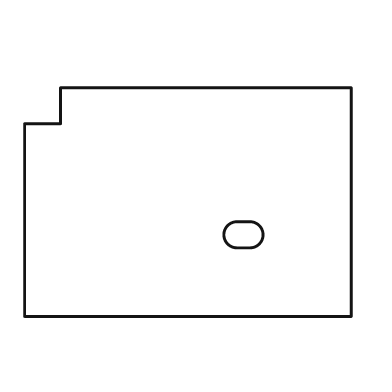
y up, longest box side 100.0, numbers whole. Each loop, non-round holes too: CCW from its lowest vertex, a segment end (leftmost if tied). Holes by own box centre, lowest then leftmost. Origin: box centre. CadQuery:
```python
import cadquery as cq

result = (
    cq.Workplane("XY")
    .moveTo(-50.0, -35.0)
    .lineTo(50.0, -35.0)
    .lineTo(50.0, 35.0)
    .lineTo(-39.0, 35.0)
    .lineTo(-39.0, 24.0)
    .lineTo(-50.0, 24.0)
    .close()
    .moveTo(15.0, -14.0)
    .lineTo(19.0, -14.0)
    .threePointArc((23.0, -10.0), (19.0, -6.0))
    .lineTo(15.0, -6.0)
    .threePointArc((11.0, -10.0), (15.0, -14.0))
    .close()
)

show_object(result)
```